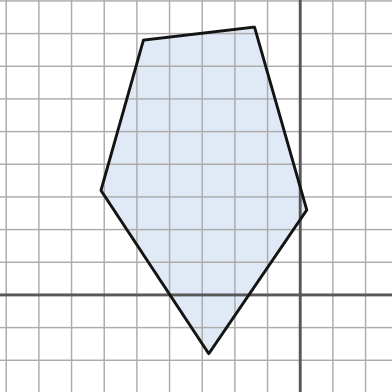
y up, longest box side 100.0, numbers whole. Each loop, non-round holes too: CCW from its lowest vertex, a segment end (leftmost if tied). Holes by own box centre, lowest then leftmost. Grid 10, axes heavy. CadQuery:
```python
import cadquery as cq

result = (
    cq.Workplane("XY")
    .moveTo(-28.0, -18.0)
    .lineTo(2.0, 26.0)
    .lineTo(-14.0, 82.0)
    .lineTo(-48.0, 78.0)
    .lineTo(-61.0, 32.0)
    .close()
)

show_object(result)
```